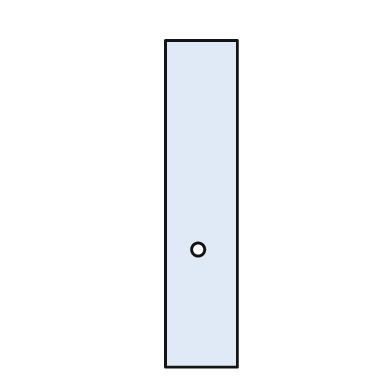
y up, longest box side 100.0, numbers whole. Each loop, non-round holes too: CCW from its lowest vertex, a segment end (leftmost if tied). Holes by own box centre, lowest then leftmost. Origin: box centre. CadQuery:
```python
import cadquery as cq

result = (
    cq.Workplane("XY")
    .moveTo(-11.0, -50.0)
    .lineTo(11.0, -50.0)
    .lineTo(11.0, 50.0)
    .lineTo(-11.0, 50.0)
    .close()
    .moveTo(-1.0, -14.0)
    .circle(2.0)
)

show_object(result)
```